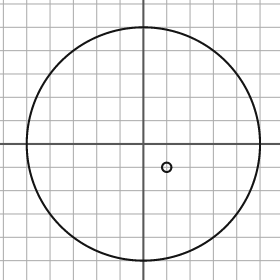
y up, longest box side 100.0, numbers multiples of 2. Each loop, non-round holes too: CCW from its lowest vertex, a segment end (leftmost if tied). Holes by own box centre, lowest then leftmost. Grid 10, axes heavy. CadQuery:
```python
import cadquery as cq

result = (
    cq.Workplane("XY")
    .moveTo(0.0, 0.0)
    .circle(50.0)
    .moveTo(10.0, -10.0)
    .circle(2.0)
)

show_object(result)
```